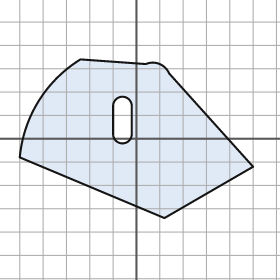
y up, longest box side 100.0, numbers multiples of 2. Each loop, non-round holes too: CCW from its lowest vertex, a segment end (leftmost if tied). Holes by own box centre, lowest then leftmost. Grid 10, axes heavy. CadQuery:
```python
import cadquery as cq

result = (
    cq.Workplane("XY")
    .moveTo(12.0, -34.0)
    .lineTo(50.0, -12.0)
    .lineTo(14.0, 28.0)
    .threePointArc((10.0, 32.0), (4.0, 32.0))
    .lineTo(-24.0, 34.0)
    .threePointArc((-42.0, 16.0), (-50.0, -8.0))
    .close()
    .moveTo(-10.0, 2.0)
    .threePointArc((-6.0, -2.0), (-2.0, 2.0))
    .lineTo(-2.0, 14.0)
    .threePointArc((-6.0, 18.0), (-10.0, 14.0))
    .close()
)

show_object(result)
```